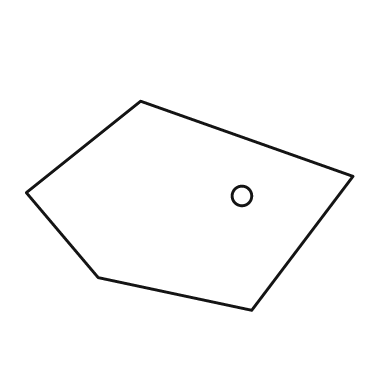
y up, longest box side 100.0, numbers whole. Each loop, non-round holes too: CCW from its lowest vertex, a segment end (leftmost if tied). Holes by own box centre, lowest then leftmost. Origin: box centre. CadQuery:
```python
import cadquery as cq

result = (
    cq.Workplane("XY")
    .moveTo(19.0, -32.0)
    .lineTo(50.0, 9.0)
    .lineTo(-15.0, 32.0)
    .lineTo(-50.0, 4.0)
    .lineTo(-28.0, -22.0)
    .close()
    .moveTo(16.0, 3.0)
    .circle(3.0)
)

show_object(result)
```